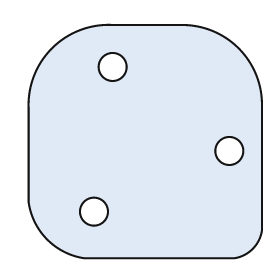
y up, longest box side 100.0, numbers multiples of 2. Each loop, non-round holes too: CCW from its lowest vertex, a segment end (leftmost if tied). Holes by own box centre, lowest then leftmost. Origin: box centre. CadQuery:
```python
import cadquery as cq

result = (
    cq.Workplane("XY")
    .moveTo(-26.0, -50.0)
    .lineTo(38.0, -50.0)
    .threePointArc((46.0, -46.0), (50.0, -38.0))
    .lineTo(50.0, 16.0)
    .threePointArc((40.0, 40.0), (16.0, 50.0))
    .lineTo(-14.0, 50.0)
    .threePointArc((-40.0, 40.0), (-50.0, 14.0))
    .lineTo(-50.0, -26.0)
    .threePointArc((-42.0, -42.0), (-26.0, -50.0))
    .close()
    .moveTo(-22.0, -30.0)
    .circle(6.0)
    .moveTo(36.0, -4.0)
    .circle(6.0)
    .moveTo(-14.0, 32.0)
    .circle(6.0)
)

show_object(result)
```